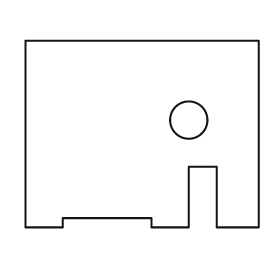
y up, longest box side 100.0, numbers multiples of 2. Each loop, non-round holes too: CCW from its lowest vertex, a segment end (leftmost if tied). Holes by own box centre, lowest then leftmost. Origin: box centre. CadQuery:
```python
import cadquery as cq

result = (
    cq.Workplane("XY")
    .moveTo(-50.0, -40.0)
    .lineTo(-34.0, -40.0)
    .lineTo(-34.0, -36.0)
    .lineTo(4.0, -36.0)
    .lineTo(4.0, -40.0)
    .lineTo(20.0, -40.0)
    .lineTo(20.0, -14.0)
    .lineTo(32.0, -14.0)
    .lineTo(32.0, -40.0)
    .lineTo(50.0, -40.0)
    .lineTo(50.0, 40.0)
    .lineTo(-50.0, 40.0)
    .close()
    .moveTo(20.0, 6.0)
    .circle(8.0)
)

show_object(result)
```